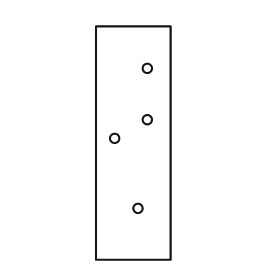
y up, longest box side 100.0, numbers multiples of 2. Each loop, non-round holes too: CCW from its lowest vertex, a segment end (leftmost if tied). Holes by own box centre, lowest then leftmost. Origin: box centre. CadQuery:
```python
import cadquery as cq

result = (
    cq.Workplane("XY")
    .moveTo(-16.0, -50.0)
    .lineTo(16.0, -50.0)
    .lineTo(16.0, 50.0)
    .lineTo(-16.0, 50.0)
    .close()
    .moveTo(2.0, -28.0)
    .circle(2.0)
    .moveTo(-8.0, 2.0)
    .circle(2.0)
    .moveTo(6.0, 10.0)
    .circle(2.0)
    .moveTo(6.0, 32.0)
    .circle(2.0)
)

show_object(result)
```